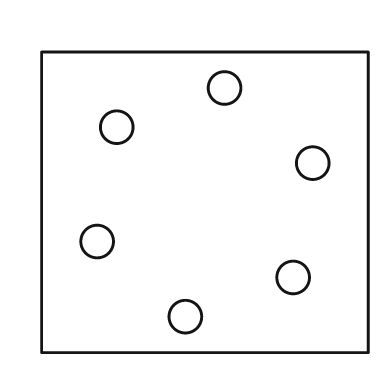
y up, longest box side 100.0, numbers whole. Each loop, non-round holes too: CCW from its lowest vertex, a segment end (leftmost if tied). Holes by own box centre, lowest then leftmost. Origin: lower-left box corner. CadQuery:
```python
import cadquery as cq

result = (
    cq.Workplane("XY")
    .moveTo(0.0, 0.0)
    .lineTo(100.0, 0.0)
    .lineTo(100.0, 92.0)
    .lineTo(0.0, 92.0)
    .close()
    .moveTo(44.0, 11.0)
    .circle(5.0)
    .moveTo(77.0, 23.0)
    .circle(5.0)
    .moveTo(17.0, 34.0)
    .circle(5.0)
    .moveTo(83.0, 58.0)
    .circle(5.0)
    .moveTo(23.0, 69.0)
    .circle(5.0)
    .moveTo(56.0, 81.0)
    .circle(5.0)
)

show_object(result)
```